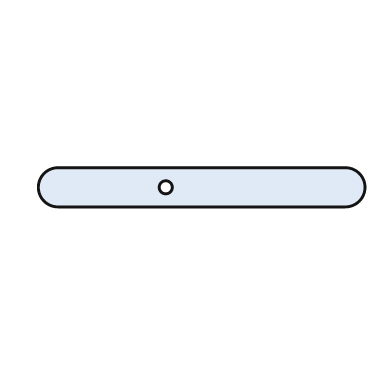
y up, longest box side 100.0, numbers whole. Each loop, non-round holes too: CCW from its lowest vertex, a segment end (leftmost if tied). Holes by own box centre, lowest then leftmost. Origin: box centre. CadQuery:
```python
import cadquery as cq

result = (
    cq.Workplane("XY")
    .moveTo(-44.0, -6.0)
    .lineTo(44.0, -6.0)
    .threePointArc((50.0, 0.0), (44.0, 6.0))
    .lineTo(-44.0, 6.0)
    .threePointArc((-50.0, 0.0), (-44.0, -6.0))
    .close()
    .moveTo(-11.0, 0.0)
    .circle(2.0)
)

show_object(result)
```